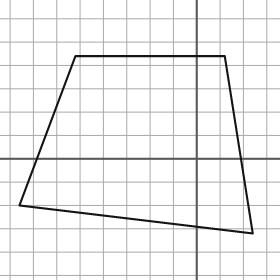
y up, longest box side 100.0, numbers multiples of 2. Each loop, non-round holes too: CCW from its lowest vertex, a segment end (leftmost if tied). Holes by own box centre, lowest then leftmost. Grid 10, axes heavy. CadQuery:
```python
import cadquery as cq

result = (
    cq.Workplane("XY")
    .moveTo(24.0, -32.0)
    .lineTo(12.0, 44.0)
    .lineTo(-52.0, 44.0)
    .lineTo(-76.0, -20.0)
    .close()
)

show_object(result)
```